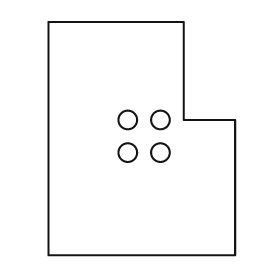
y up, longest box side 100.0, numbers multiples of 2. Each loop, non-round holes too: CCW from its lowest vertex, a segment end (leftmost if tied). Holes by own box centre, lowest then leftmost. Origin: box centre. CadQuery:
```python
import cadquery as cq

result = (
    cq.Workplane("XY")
    .moveTo(-40.0, -50.0)
    .lineTo(40.0, -50.0)
    .lineTo(40.0, 8.0)
    .lineTo(18.0, 8.0)
    .lineTo(18.0, 50.0)
    .lineTo(-40.0, 50.0)
    .close()
    .moveTo(-6.0, -6.0)
    .circle(4.0)
    .moveTo(8.0, -6.0)
    .circle(4.0)
    .moveTo(-6.0, 8.0)
    .circle(4.0)
    .moveTo(8.0, 8.0)
    .circle(4.0)
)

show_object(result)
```